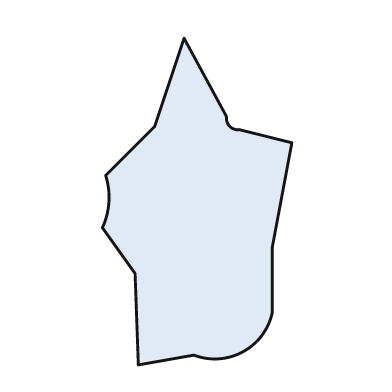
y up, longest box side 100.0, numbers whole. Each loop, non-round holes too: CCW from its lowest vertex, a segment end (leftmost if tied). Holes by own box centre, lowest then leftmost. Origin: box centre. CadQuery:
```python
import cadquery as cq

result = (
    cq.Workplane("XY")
    .moveTo(-18.0, -50.0)
    .lineTo(-1.0, -47.0)
    .threePointArc((14.0, -46.0), (23.0, -34.0))
    .lineTo(23.0, -14.0)
    .lineTo(29.0, 18.0)
    .lineTo(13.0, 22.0)
    .threePointArc((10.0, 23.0), (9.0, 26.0))
    .lineTo(-4.0, 50.0)
    .lineTo(-13.0, 23.0)
    .lineTo(-28.0, 8.0)
    .threePointArc((-27.0, 0.0), (-29.0, -8.0))
    .lineTo(-19.0, -22.0)
    .close()
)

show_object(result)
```